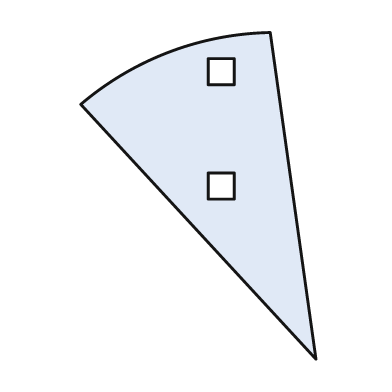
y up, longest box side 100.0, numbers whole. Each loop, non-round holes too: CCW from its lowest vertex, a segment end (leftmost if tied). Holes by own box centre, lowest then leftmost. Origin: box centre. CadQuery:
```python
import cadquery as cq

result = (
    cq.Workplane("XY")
    .moveTo(36.0, -50.0)
    .lineTo(22.0, 50.0)
    .threePointArc((-9.0, 44.0), (-36.0, 28.0))
    .close()
    .moveTo(3.0, -1.0)
    .lineTo(11.0, -1.0)
    .lineTo(11.0, 7.0)
    .lineTo(3.0, 7.0)
    .close()
    .moveTo(3.0, 34.0)
    .lineTo(11.0, 34.0)
    .lineTo(11.0, 42.0)
    .lineTo(3.0, 42.0)
    .close()
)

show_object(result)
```